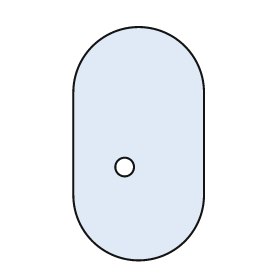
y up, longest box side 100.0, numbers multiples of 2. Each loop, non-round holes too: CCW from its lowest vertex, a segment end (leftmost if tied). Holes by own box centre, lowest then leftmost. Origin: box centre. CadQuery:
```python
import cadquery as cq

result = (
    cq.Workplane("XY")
    .moveTo(-28.0, -22.0)
    .threePointArc((0.0, -50.0), (28.0, -22.0))
    .lineTo(28.0, 22.0)
    .threePointArc((0.0, 50.0), (-28.0, 22.0))
    .close()
    .moveTo(-6.0, -10.0)
    .circle(4.0)
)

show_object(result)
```